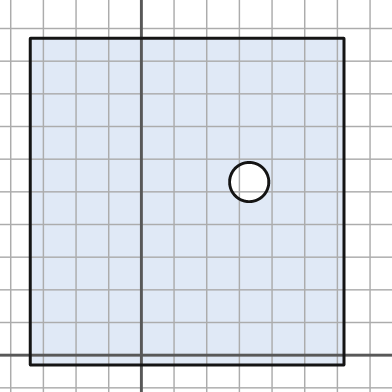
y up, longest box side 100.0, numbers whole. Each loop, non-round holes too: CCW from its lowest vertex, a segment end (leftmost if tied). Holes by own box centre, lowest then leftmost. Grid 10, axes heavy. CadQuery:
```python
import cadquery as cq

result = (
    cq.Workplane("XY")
    .moveTo(-34.0, -3.0)
    .lineTo(62.0, -3.0)
    .lineTo(62.0, 97.0)
    .lineTo(-34.0, 97.0)
    .close()
    .moveTo(33.0, 53.0)
    .circle(6.0)
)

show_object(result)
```